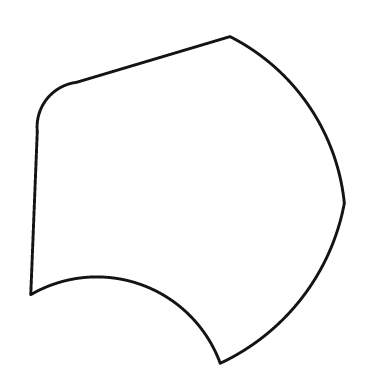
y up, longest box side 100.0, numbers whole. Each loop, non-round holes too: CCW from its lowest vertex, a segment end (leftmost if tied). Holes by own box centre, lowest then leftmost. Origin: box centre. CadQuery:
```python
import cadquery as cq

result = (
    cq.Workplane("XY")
    .moveTo(10.0, -50.0)
    .threePointArc((35.0, -30.0), (48.0, -1.0))
    .threePointArc((37.0, 29.0), (13.0, 50.0))
    .lineTo(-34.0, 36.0)
    .threePointArc((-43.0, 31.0), (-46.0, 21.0))
    .lineTo(-48.0, -29.0)
    .threePointArc((-14.0, -26.0), (10.0, -50.0))
    .close()
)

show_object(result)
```